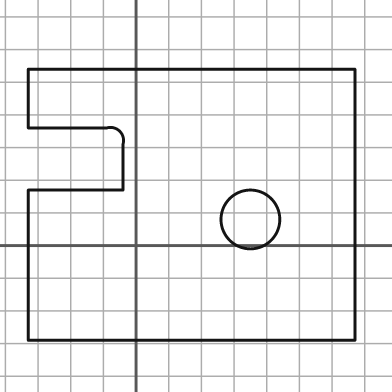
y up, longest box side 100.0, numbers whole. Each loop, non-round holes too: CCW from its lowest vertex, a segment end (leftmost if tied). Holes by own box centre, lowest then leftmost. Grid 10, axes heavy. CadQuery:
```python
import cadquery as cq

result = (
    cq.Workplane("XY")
    .moveTo(-33.0, -29.0)
    .lineTo(67.0, -29.0)
    .lineTo(67.0, 54.0)
    .lineTo(-33.0, 54.0)
    .lineTo(-33.0, 36.0)
    .lineTo(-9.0, 36.0)
    .threePointArc((-5.0, 35.0), (-4.0, 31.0))
    .lineTo(-4.0, 17.0)
    .lineTo(-33.0, 17.0)
    .close()
    .moveTo(35.0, 8.0)
    .circle(9.0)
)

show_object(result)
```